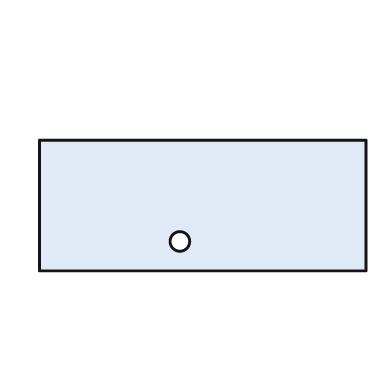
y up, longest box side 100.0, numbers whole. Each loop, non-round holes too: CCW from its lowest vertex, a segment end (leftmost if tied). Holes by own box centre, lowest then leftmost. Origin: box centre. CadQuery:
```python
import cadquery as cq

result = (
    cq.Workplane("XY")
    .moveTo(-50.0, -20.0)
    .lineTo(50.0, -20.0)
    .lineTo(50.0, 20.0)
    .lineTo(-50.0, 20.0)
    .close()
    .moveTo(-7.0, -11.0)
    .circle(3.0)
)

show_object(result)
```